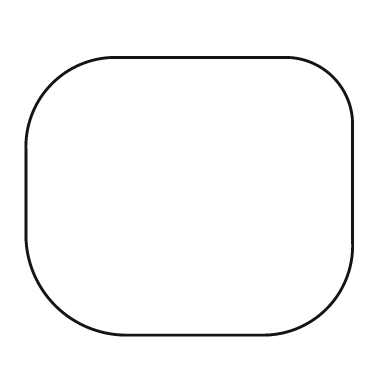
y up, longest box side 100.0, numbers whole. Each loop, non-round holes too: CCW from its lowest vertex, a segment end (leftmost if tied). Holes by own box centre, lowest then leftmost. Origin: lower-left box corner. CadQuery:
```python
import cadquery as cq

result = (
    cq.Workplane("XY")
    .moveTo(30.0, 0.0)
    .lineTo(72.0, 0.0)
    .threePointArc((92.0, 8.0), (100.0, 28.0))
    .lineTo(100.0, 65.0)
    .threePointArc((94.0, 79.0), (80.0, 85.0))
    .lineTo(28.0, 85.0)
    .threePointArc((8.0, 77.0), (0.0, 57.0))
    .lineTo(0.0, 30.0)
    .threePointArc((9.0, 9.0), (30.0, 0.0))
    .close()
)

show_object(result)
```